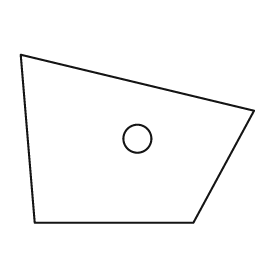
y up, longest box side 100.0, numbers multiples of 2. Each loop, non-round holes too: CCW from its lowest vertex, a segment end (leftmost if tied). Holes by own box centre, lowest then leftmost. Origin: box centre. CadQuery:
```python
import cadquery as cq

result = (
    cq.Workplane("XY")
    .moveTo(-44.0, -36.0)
    .lineTo(24.0, -36.0)
    .lineTo(50.0, 12.0)
    .lineTo(-50.0, 36.0)
    .close()
    .moveTo(0.0, 0.0)
    .circle(6.0)
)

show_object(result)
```